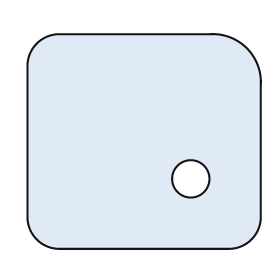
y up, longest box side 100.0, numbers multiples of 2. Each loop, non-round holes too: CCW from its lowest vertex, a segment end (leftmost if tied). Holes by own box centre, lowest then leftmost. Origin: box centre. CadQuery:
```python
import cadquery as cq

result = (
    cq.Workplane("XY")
    .moveTo(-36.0, -46.0)
    .lineTo(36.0, -46.0)
    .threePointArc((46.0, -42.0), (50.0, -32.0))
    .lineTo(50.0, 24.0)
    .threePointArc((44.0, 40.0), (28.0, 46.0))
    .lineTo(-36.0, 46.0)
    .threePointArc((-46.0, 42.0), (-50.0, 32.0))
    .lineTo(-50.0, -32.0)
    .threePointArc((-46.0, -42.0), (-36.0, -46.0))
    .close()
    .moveTo(20.0, -16.0)
    .circle(8.0)
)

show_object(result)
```